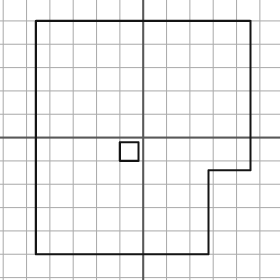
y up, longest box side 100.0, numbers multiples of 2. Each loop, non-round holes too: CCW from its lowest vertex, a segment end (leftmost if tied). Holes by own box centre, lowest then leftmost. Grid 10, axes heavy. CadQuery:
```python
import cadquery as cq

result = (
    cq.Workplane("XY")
    .moveTo(-46.0, -50.0)
    .lineTo(28.0, -50.0)
    .lineTo(28.0, -14.0)
    .lineTo(46.0, -14.0)
    .lineTo(46.0, 50.0)
    .lineTo(-46.0, 50.0)
    .close()
    .moveTo(-10.0, -10.0)
    .lineTo(-2.0, -10.0)
    .lineTo(-2.0, -2.0)
    .lineTo(-10.0, -2.0)
    .close()
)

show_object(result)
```